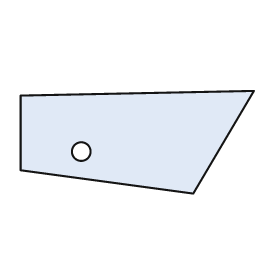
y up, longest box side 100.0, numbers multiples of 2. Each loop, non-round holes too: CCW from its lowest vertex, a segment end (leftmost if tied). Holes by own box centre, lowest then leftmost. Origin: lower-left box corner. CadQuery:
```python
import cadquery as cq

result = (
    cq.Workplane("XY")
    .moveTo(74.0, 0.0)
    .lineTo(100.0, 44.0)
    .lineTo(0.0, 42.0)
    .lineTo(0.0, 10.0)
    .close()
    .moveTo(26.0, 18.0)
    .circle(4.0)
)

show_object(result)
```